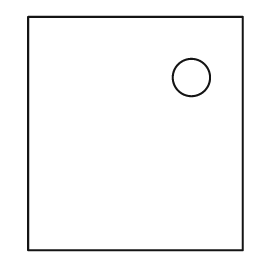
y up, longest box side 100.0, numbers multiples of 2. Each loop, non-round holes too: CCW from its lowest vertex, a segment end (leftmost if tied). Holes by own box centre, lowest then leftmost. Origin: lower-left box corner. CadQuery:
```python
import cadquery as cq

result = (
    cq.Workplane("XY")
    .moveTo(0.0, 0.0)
    .lineTo(92.0, 0.0)
    .lineTo(92.0, 100.0)
    .lineTo(0.0, 100.0)
    .close()
    .moveTo(70.0, 74.0)
    .circle(8.0)
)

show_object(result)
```